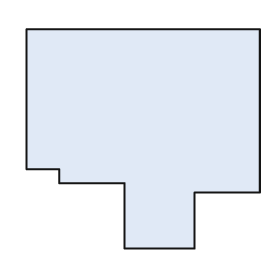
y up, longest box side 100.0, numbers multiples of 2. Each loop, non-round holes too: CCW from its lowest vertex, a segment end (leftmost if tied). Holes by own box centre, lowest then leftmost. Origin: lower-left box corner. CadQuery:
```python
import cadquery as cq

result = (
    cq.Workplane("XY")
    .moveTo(42.0, 0.0)
    .lineTo(72.0, 0.0)
    .lineTo(72.0, 24.0)
    .lineTo(100.0, 24.0)
    .lineTo(100.0, 94.0)
    .lineTo(0.0, 94.0)
    .lineTo(0.0, 34.0)
    .lineTo(14.0, 34.0)
    .lineTo(14.0, 28.0)
    .lineTo(42.0, 28.0)
    .close()
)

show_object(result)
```